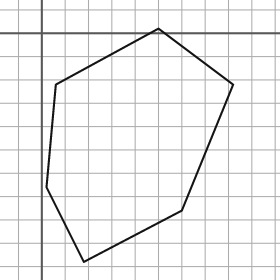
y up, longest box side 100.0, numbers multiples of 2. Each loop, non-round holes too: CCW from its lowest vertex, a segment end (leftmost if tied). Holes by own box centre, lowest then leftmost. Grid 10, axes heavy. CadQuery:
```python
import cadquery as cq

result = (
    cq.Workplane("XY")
    .moveTo(18.0, -98.0)
    .lineTo(60.0, -76.0)
    .lineTo(82.0, -22.0)
    .lineTo(50.0, 2.0)
    .lineTo(6.0, -22.0)
    .lineTo(2.0, -66.0)
    .close()
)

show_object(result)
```